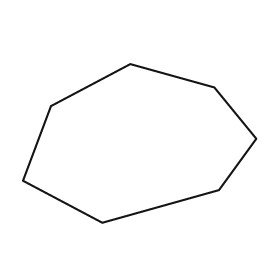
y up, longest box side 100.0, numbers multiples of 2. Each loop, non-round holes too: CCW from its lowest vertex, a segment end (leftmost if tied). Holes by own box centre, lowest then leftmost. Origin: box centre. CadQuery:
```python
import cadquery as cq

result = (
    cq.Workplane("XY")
    .moveTo(-16.0, -34.0)
    .lineTo(34.0, -20.0)
    .lineTo(50.0, 2.0)
    .lineTo(32.0, 24.0)
    .lineTo(-4.0, 34.0)
    .lineTo(-38.0, 16.0)
    .lineTo(-50.0, -16.0)
    .close()
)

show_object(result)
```